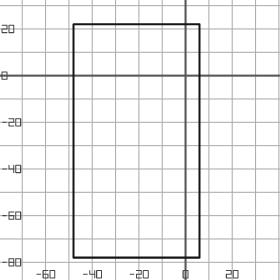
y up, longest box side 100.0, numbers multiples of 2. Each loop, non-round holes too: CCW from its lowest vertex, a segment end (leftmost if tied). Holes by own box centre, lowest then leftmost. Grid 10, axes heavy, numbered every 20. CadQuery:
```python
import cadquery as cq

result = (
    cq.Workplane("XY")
    .moveTo(-48.0, -78.0)
    .lineTo(6.0, -78.0)
    .lineTo(6.0, 22.0)
    .lineTo(-48.0, 22.0)
    .close()
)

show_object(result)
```